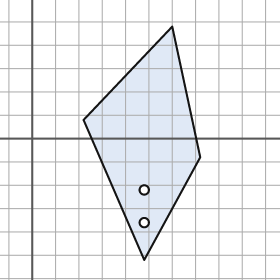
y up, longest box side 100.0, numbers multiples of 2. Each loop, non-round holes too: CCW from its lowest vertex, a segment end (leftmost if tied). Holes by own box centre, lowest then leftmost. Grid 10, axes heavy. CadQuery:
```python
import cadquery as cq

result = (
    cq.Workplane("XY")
    .moveTo(48.0, -52.0)
    .lineTo(72.0, -8.0)
    .lineTo(60.0, 48.0)
    .lineTo(22.0, 8.0)
    .close()
    .moveTo(48.0, -36.0)
    .circle(2.0)
    .moveTo(48.0, -22.0)
    .circle(2.0)
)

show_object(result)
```